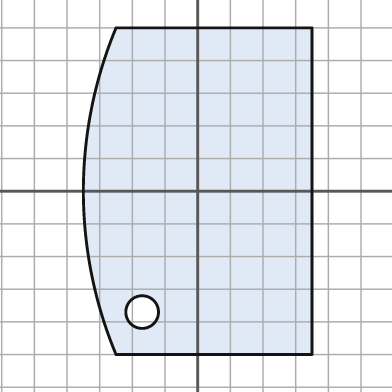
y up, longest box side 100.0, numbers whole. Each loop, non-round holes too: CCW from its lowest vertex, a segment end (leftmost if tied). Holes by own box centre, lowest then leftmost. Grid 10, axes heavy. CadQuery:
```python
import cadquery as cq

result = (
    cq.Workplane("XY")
    .moveTo(-25.0, -50.0)
    .lineTo(35.0, -50.0)
    .lineTo(35.0, 50.0)
    .lineTo(-25.0, 50.0)
    .threePointArc((-35.0, 0.0), (-25.0, -50.0))
    .close()
    .moveTo(-17.0, -37.0)
    .circle(5.0)
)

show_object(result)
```